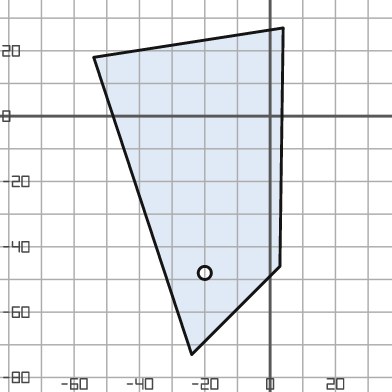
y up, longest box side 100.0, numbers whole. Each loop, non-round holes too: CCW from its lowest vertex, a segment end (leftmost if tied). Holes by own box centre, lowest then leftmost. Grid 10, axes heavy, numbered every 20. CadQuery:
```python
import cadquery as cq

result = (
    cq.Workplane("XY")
    .moveTo(-24.0, -73.0)
    .lineTo(3.0, -46.0)
    .lineTo(4.0, 27.0)
    .lineTo(-54.0, 18.0)
    .close()
    .moveTo(-20.0, -48.0)
    .circle(2.0)
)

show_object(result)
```